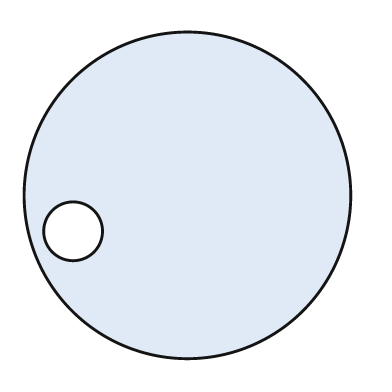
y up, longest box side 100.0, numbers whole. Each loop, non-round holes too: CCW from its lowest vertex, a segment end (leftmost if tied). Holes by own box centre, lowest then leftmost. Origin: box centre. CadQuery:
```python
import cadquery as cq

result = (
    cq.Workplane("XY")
    .moveTo(0.0, 0.0)
    .circle(50.0)
    .moveTo(-35.0, -11.0)
    .circle(9.0)
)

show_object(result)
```